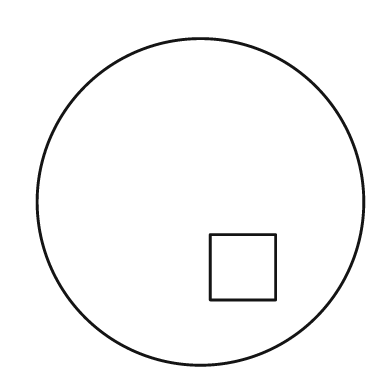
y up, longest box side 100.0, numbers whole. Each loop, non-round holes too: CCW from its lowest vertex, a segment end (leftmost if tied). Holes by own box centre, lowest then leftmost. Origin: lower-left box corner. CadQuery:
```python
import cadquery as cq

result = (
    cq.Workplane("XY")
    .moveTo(50.0, 50.0)
    .circle(50.0)
    .moveTo(53.0, 20.0)
    .lineTo(73.0, 20.0)
    .lineTo(73.0, 40.0)
    .lineTo(53.0, 40.0)
    .close()
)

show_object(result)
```